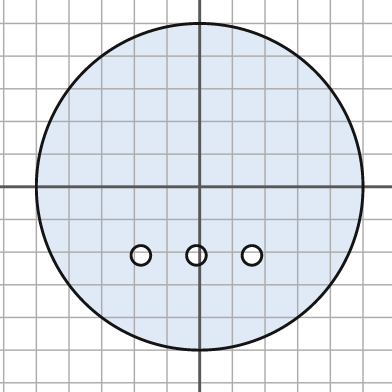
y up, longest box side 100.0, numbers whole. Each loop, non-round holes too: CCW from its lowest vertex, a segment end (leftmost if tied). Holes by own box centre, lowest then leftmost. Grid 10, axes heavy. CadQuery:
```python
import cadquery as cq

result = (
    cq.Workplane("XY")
    .moveTo(0.0, 0.0)
    .circle(50.0)
    .moveTo(-18.0, -21.0)
    .circle(3.0)
    .moveTo(-1.0, -21.0)
    .circle(3.0)
    .moveTo(16.0, -21.0)
    .circle(3.0)
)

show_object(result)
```